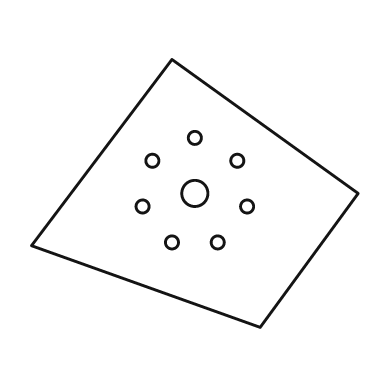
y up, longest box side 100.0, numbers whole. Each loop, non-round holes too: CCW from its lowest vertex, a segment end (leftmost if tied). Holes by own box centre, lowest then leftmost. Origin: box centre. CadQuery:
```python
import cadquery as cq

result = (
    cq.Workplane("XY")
    .moveTo(20.0, -41.0)
    .lineTo(50.0, 0.0)
    .lineTo(-7.0, 41.0)
    .lineTo(-50.0, -16.0)
    .close()
    .moveTo(-7.0, -15.0)
    .circle(2.0)
    .moveTo(7.0, -15.0)
    .circle(2.0)
    .moveTo(-16.0, -4.0)
    .circle(2.0)
    .moveTo(16.0, -4.0)
    .circle(2.0)
    .moveTo(0.0, 0.0)
    .circle(4.0)
    .moveTo(-13.0, 10.0)
    .circle(2.0)
    .moveTo(13.0, 10.0)
    .circle(2.0)
    .moveTo(0.0, 17.0)
    .circle(2.0)
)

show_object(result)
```